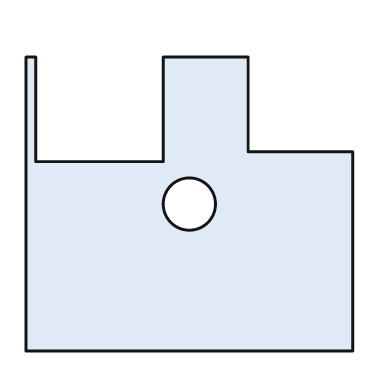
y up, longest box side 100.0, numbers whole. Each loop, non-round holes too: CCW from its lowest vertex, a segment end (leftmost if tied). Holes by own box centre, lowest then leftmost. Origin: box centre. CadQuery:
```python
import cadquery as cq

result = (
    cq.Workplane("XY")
    .moveTo(-50.0, -45.0)
    .lineTo(50.0, -45.0)
    .lineTo(50.0, 16.0)
    .lineTo(18.0, 16.0)
    .lineTo(18.0, 45.0)
    .lineTo(-8.0, 45.0)
    .lineTo(-8.0, 13.0)
    .lineTo(-47.0, 13.0)
    .lineTo(-47.0, 45.0)
    .lineTo(-50.0, 45.0)
    .close()
    .moveTo(0.0, 0.0)
    .circle(8.0)
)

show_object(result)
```